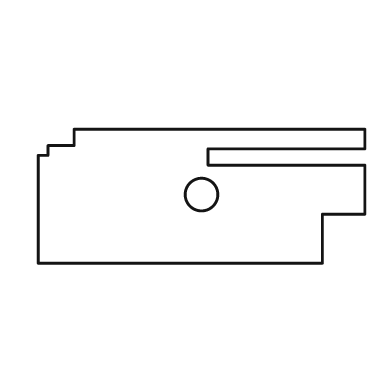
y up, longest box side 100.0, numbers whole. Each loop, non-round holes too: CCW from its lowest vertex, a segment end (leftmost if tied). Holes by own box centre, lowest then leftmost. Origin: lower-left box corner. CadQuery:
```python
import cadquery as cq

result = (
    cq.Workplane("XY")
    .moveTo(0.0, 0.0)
    .lineTo(87.0, 0.0)
    .lineTo(87.0, 15.0)
    .lineTo(100.0, 15.0)
    .lineTo(100.0, 30.0)
    .lineTo(52.0, 30.0)
    .lineTo(52.0, 35.0)
    .lineTo(100.0, 35.0)
    .lineTo(100.0, 41.0)
    .lineTo(11.0, 41.0)
    .lineTo(11.0, 36.0)
    .lineTo(3.0, 36.0)
    .lineTo(3.0, 33.0)
    .lineTo(0.0, 33.0)
    .close()
    .moveTo(50.0, 21.0)
    .circle(5.0)
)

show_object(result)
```